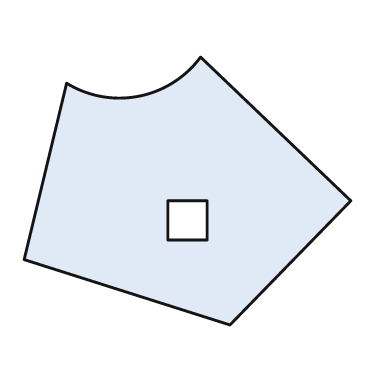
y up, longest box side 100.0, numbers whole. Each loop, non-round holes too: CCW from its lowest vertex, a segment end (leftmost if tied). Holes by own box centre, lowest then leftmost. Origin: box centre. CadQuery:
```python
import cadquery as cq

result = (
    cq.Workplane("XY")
    .moveTo(13.0, -41.0)
    .lineTo(50.0, -3.0)
    .lineTo(4.0, 41.0)
    .threePointArc((-15.0, 29.0), (-37.0, 33.0))
    .lineTo(-50.0, -21.0)
    .close()
    .moveTo(-6.0, -15.0)
    .lineTo(6.0, -15.0)
    .lineTo(6.0, -3.0)
    .lineTo(-6.0, -3.0)
    .close()
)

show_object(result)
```